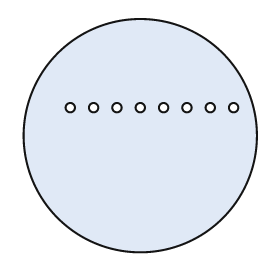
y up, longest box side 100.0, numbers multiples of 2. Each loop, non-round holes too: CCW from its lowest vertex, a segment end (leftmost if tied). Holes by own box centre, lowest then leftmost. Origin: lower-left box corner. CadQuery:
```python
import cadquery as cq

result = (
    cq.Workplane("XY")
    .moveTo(50.0, 50.0)
    .circle(50.0)
    .moveTo(20.0, 62.0)
    .circle(2.0)
    .moveTo(30.0, 62.0)
    .circle(2.0)
    .moveTo(40.0, 62.0)
    .circle(2.0)
    .moveTo(50.0, 62.0)
    .circle(2.0)
    .moveTo(60.0, 62.0)
    .circle(2.0)
    .moveTo(70.0, 62.0)
    .circle(2.0)
    .moveTo(80.0, 62.0)
    .circle(2.0)
    .moveTo(90.0, 62.0)
    .circle(2.0)
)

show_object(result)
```